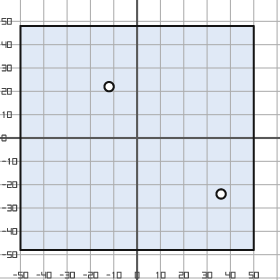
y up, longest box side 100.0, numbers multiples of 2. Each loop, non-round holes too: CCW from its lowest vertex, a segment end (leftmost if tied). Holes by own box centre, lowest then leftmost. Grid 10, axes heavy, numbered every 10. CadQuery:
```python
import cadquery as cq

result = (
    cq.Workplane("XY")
    .moveTo(-50.0, -48.0)
    .lineTo(50.0, -48.0)
    .lineTo(50.0, 48.0)
    .lineTo(-50.0, 48.0)
    .close()
    .moveTo(36.0, -24.0)
    .circle(2.0)
    .moveTo(-12.0, 22.0)
    .circle(2.0)
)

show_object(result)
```